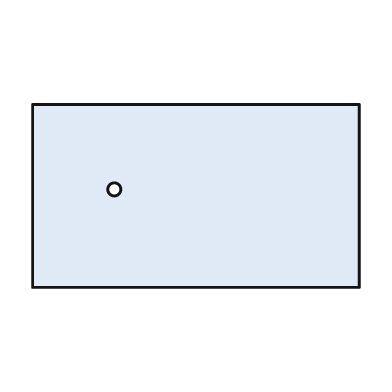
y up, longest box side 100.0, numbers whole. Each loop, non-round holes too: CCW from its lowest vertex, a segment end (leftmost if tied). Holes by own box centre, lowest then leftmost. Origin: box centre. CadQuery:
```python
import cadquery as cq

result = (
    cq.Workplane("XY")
    .moveTo(-50.0, -28.0)
    .lineTo(50.0, -28.0)
    .lineTo(50.0, 28.0)
    .lineTo(-50.0, 28.0)
    .close()
    .moveTo(-25.0, 2.0)
    .circle(2.0)
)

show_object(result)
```